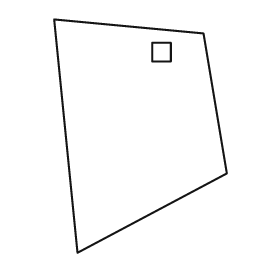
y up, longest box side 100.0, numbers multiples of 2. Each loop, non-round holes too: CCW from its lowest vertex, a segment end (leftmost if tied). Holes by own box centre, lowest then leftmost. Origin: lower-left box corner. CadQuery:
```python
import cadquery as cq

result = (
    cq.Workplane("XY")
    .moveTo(10.0, 0.0)
    .lineTo(74.0, 34.0)
    .lineTo(64.0, 94.0)
    .lineTo(0.0, 100.0)
    .close()
    .moveTo(42.0, 82.0)
    .lineTo(50.0, 82.0)
    .lineTo(50.0, 90.0)
    .lineTo(42.0, 90.0)
    .close()
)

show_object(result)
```